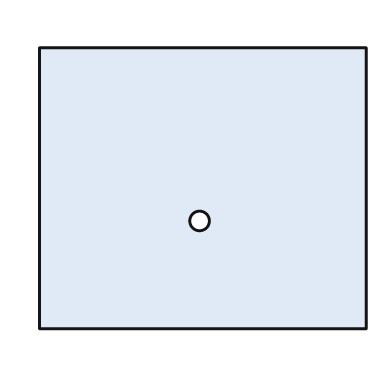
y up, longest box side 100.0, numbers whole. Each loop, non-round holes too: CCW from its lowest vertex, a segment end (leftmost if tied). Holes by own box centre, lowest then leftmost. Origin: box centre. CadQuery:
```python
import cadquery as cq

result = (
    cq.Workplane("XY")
    .moveTo(-50.0, -43.0)
    .lineTo(50.0, -43.0)
    .lineTo(50.0, 43.0)
    .lineTo(-50.0, 43.0)
    .close()
    .moveTo(-1.0, -10.0)
    .circle(3.0)
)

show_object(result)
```